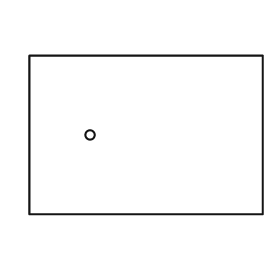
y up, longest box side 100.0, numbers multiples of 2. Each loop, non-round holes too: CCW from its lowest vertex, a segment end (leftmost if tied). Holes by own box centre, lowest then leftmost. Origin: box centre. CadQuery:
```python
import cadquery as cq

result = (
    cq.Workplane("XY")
    .moveTo(-50.0, -34.0)
    .lineTo(50.0, -34.0)
    .lineTo(50.0, 34.0)
    .lineTo(-50.0, 34.0)
    .close()
    .moveTo(-24.0, 0.0)
    .circle(2.0)
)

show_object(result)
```